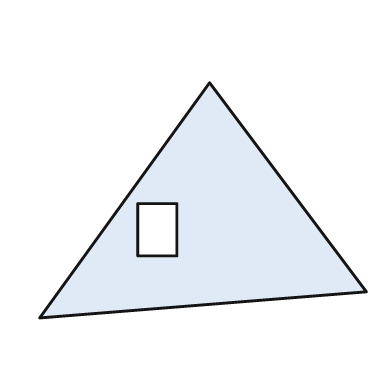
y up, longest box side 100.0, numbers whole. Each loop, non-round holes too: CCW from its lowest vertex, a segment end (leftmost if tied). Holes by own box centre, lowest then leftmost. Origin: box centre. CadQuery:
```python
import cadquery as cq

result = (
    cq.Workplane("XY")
    .moveTo(-50.0, -36.0)
    .lineTo(50.0, -28.0)
    .lineTo(2.0, 36.0)
    .close()
    .moveTo(-20.0, -17.0)
    .lineTo(-8.0, -17.0)
    .lineTo(-8.0, -1.0)
    .lineTo(-20.0, -1.0)
    .close()
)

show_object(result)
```